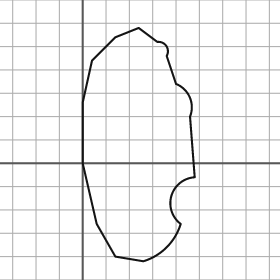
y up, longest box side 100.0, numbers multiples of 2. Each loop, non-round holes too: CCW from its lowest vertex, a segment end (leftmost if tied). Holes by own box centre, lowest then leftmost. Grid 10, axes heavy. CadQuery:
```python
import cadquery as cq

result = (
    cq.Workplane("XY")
    .moveTo(26.0, -42.0)
    .threePointArc((36.0, -36.0), (42.0, -26.0))
    .threePointArc((38.0, -14.0), (48.0, -6.0))
    .lineTo(46.0, 20.0)
    .threePointArc((46.0, 28.0), (40.0, 34.0))
    .lineTo(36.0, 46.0)
    .threePointArc((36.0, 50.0), (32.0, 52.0))
    .lineTo(24.0, 58.0)
    .lineTo(14.0, 54.0)
    .lineTo(4.0, 44.0)
    .lineTo(0.0, 26.0)
    .lineTo(0.0, 0.0)
    .lineTo(6.0, -26.0)
    .lineTo(14.0, -40.0)
    .close()
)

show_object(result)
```